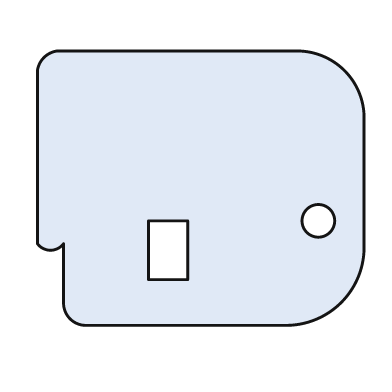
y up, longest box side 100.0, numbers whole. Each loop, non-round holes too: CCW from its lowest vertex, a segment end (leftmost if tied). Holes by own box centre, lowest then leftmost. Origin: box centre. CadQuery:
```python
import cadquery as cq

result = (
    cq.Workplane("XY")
    .moveTo(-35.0, -42.0)
    .lineTo(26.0, -42.0)
    .threePointArc((43.0, -35.0), (50.0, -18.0))
    .lineTo(50.0, 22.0)
    .threePointArc((44.0, 36.0), (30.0, 42.0))
    .lineTo(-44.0, 42.0)
    .threePointArc((-48.0, 40.0), (-50.0, 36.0))
    .lineTo(-50.0, -17.0)
    .threePointArc((-46.0, -19.0), (-42.0, -17.0))
    .lineTo(-42.0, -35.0)
    .threePointArc((-40.0, -40.0), (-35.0, -42.0))
    .close()
    .moveTo(-16.0, -28.0)
    .lineTo(-4.0, -28.0)
    .lineTo(-4.0, -10.0)
    .lineTo(-16.0, -10.0)
    .close()
    .moveTo(36.0, -10.0)
    .circle(5.0)
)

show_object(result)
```